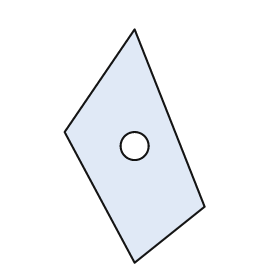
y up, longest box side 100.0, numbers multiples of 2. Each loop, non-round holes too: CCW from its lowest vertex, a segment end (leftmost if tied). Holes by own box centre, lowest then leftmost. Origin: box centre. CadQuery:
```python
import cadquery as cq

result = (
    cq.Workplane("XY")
    .moveTo(0.0, -50.0)
    .lineTo(30.0, -26.0)
    .lineTo(0.0, 50.0)
    .lineTo(-30.0, 6.0)
    .close()
    .moveTo(0.0, 0.0)
    .circle(6.0)
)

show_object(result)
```